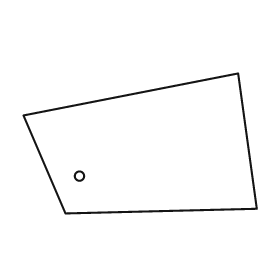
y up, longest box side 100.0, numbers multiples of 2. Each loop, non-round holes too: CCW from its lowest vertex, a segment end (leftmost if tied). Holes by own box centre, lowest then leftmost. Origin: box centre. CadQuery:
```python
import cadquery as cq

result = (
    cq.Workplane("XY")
    .moveTo(-32.0, -30.0)
    .lineTo(50.0, -28.0)
    .lineTo(42.0, 30.0)
    .lineTo(-50.0, 12.0)
    .close()
    .moveTo(-26.0, -14.0)
    .circle(2.0)
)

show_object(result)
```